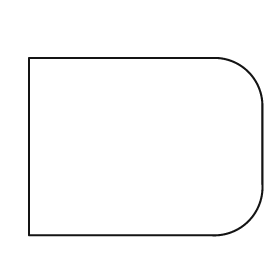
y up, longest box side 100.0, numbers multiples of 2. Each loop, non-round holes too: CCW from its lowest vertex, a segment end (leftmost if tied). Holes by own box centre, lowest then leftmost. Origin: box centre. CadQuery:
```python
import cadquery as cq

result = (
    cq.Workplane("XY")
    .moveTo(-50.0, -38.0)
    .lineTo(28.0, -38.0)
    .threePointArc((44.0, -32.0), (50.0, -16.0))
    .lineTo(50.0, 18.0)
    .threePointArc((44.0, 32.0), (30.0, 38.0))
    .lineTo(-50.0, 38.0)
    .close()
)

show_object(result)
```